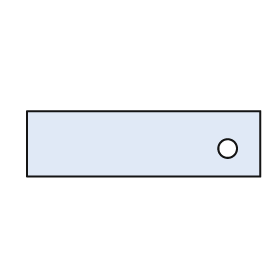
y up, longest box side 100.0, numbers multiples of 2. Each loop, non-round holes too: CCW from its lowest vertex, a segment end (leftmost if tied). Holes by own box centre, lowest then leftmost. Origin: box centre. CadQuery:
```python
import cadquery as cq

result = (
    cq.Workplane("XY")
    .moveTo(-50.0, -14.0)
    .lineTo(50.0, -14.0)
    .lineTo(50.0, 14.0)
    .lineTo(-50.0, 14.0)
    .close()
    .moveTo(36.0, -2.0)
    .circle(4.0)
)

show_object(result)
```